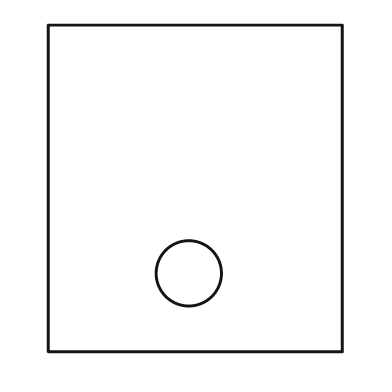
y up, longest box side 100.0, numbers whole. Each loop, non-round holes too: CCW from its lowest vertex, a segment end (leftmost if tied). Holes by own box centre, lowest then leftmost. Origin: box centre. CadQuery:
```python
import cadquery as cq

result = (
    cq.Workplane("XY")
    .moveTo(-45.0, -50.0)
    .lineTo(45.0, -50.0)
    .lineTo(45.0, 50.0)
    .lineTo(-45.0, 50.0)
    .close()
    .moveTo(-2.0, -26.0)
    .circle(10.0)
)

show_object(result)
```